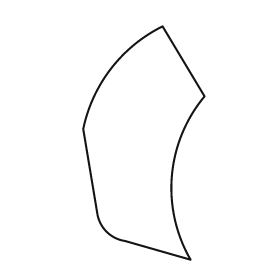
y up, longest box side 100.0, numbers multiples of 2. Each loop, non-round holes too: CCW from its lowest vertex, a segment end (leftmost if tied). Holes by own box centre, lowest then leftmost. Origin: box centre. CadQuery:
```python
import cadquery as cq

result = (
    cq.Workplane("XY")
    .moveTo(20.0, -50.0)
    .threePointArc((12.0, -14.0), (26.0, 20.0))
    .lineTo(8.0, 50.0)
    .threePointArc((-14.0, 32.0), (-26.0, 6.0))
    .lineTo(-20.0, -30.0)
    .threePointArc((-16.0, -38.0), (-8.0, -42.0))
    .close()
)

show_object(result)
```